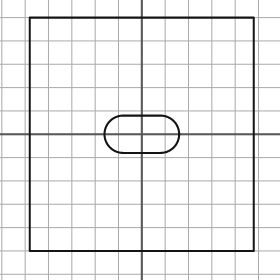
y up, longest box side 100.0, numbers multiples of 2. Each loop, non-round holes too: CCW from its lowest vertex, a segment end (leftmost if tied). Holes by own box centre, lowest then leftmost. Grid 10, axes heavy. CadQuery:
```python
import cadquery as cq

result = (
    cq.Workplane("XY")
    .moveTo(-48.0, -50.0)
    .lineTo(48.0, -50.0)
    .lineTo(48.0, 50.0)
    .lineTo(-48.0, 50.0)
    .close()
    .moveTo(-8.0, -8.0)
    .lineTo(8.0, -8.0)
    .threePointArc((16.0, 0.0), (8.0, 8.0))
    .lineTo(-8.0, 8.0)
    .threePointArc((-16.0, 0.0), (-8.0, -8.0))
    .close()
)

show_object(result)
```